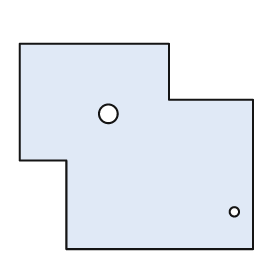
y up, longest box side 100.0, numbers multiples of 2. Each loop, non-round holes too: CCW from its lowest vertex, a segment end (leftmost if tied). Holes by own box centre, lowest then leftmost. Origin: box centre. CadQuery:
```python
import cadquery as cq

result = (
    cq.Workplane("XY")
    .moveTo(-30.0, -44.0)
    .lineTo(50.0, -44.0)
    .lineTo(50.0, 20.0)
    .lineTo(14.0, 20.0)
    .lineTo(14.0, 44.0)
    .lineTo(-50.0, 44.0)
    .lineTo(-50.0, -6.0)
    .lineTo(-30.0, -6.0)
    .close()
    .moveTo(42.0, -28.0)
    .circle(2.0)
    .moveTo(-12.0, 14.0)
    .circle(4.0)
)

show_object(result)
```